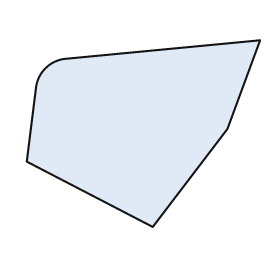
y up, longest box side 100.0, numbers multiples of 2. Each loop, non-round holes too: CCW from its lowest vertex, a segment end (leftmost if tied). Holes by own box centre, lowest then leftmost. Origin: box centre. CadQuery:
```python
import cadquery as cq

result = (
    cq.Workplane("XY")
    .moveTo(4.0, -40.0)
    .lineTo(36.0, 2.0)
    .lineTo(50.0, 40.0)
    .lineTo(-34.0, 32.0)
    .threePointArc((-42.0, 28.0), (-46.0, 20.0))
    .lineTo(-50.0, -12.0)
    .close()
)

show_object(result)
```